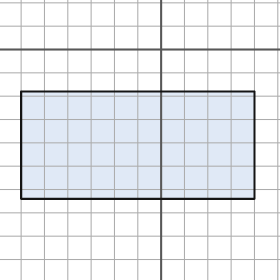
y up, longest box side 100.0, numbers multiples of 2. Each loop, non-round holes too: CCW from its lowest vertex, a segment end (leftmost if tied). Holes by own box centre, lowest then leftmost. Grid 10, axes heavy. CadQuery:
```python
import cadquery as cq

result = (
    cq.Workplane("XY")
    .moveTo(-60.0, -64.0)
    .lineTo(40.0, -64.0)
    .lineTo(40.0, -18.0)
    .lineTo(-60.0, -18.0)
    .close()
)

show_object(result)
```